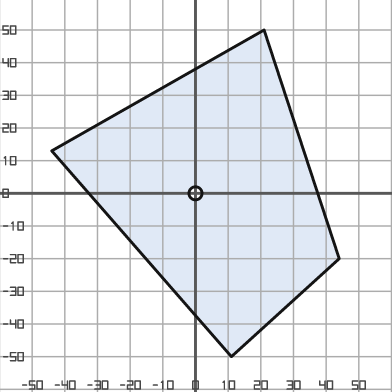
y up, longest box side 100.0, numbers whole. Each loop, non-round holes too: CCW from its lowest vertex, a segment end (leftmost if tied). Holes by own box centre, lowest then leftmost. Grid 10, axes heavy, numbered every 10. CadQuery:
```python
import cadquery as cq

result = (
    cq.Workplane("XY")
    .moveTo(11.0, -50.0)
    .lineTo(44.0, -20.0)
    .lineTo(21.0, 50.0)
    .lineTo(-44.0, 13.0)
    .close()
    .moveTo(0.0, 0.0)
    .circle(2.0)
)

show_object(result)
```